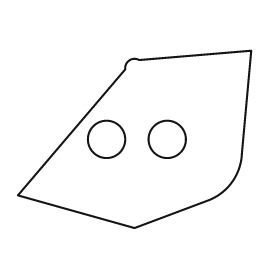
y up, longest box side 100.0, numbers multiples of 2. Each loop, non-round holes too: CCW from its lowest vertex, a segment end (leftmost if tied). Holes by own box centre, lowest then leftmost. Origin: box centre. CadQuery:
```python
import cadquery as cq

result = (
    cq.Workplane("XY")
    .moveTo(0.0, -38.0)
    .lineTo(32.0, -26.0)
    .threePointArc((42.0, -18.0), (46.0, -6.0))
    .lineTo(50.0, 38.0)
    .lineTo(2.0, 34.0)
    .threePointArc((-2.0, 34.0), (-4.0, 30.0))
    .lineTo(-50.0, -24.0)
    .close()
    .moveTo(-12.0, 0.0)
    .circle(8.0)
    .moveTo(14.0, 0.0)
    .circle(8.0)
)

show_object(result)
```